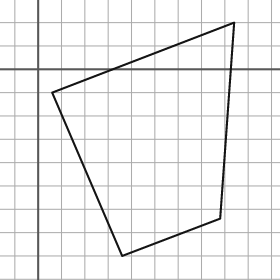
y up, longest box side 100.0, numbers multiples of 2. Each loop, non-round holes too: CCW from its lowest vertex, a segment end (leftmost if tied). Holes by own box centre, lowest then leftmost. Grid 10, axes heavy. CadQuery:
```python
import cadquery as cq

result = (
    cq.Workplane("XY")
    .moveTo(36.0, -80.0)
    .lineTo(78.0, -64.0)
    .lineTo(84.0, 20.0)
    .lineTo(6.0, -10.0)
    .close()
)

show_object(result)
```